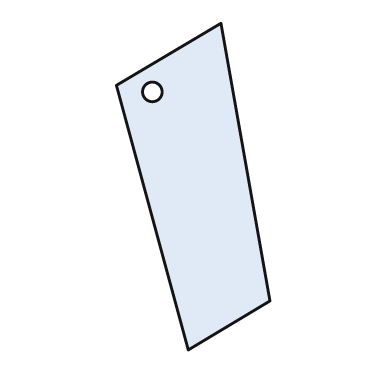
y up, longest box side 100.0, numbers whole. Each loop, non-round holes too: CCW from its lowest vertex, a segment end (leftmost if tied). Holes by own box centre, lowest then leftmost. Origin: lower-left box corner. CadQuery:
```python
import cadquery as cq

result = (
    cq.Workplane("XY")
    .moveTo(22.0, 0.0)
    .lineTo(47.0, 15.0)
    .lineTo(32.0, 100.0)
    .lineTo(0.0, 81.0)
    .close()
    .moveTo(11.0, 79.0)
    .circle(3.0)
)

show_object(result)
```